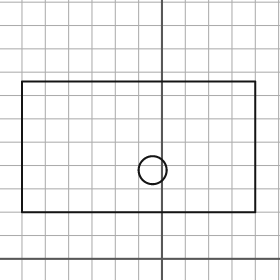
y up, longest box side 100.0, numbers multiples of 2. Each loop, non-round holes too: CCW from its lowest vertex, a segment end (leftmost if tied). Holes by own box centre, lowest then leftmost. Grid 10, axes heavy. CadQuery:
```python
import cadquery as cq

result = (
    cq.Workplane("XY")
    .moveTo(-60.0, 20.0)
    .lineTo(40.0, 20.0)
    .lineTo(40.0, 76.0)
    .lineTo(-60.0, 76.0)
    .close()
    .moveTo(-4.0, 38.0)
    .circle(6.0)
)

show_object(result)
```